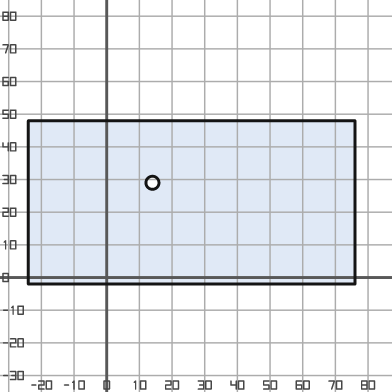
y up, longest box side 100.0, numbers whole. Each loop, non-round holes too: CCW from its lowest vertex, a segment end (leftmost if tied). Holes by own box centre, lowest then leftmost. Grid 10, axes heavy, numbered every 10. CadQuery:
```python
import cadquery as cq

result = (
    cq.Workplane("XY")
    .moveTo(-24.0, -2.0)
    .lineTo(76.0, -2.0)
    .lineTo(76.0, 48.0)
    .lineTo(-24.0, 48.0)
    .close()
    .moveTo(14.0, 29.0)
    .circle(2.0)
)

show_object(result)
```